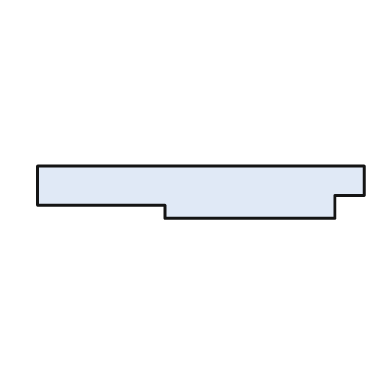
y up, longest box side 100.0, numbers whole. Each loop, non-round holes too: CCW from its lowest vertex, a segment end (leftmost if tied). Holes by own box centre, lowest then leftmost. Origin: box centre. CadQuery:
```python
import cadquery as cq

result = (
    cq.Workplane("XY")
    .moveTo(-11.0, -8.0)
    .lineTo(41.0, -8.0)
    .lineTo(41.0, -1.0)
    .lineTo(50.0, -1.0)
    .lineTo(50.0, 8.0)
    .lineTo(-50.0, 8.0)
    .lineTo(-50.0, -4.0)
    .lineTo(-11.0, -4.0)
    .close()
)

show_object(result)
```